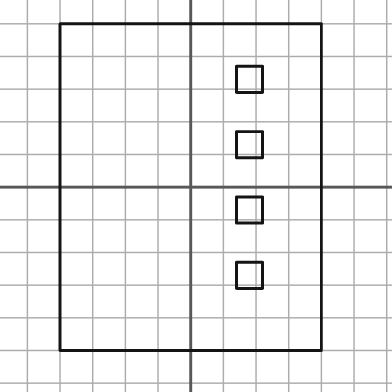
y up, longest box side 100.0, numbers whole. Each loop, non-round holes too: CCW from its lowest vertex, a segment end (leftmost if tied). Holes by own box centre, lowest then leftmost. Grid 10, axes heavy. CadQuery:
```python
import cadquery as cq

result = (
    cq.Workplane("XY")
    .moveTo(-40.0, -50.0)
    .lineTo(40.0, -50.0)
    .lineTo(40.0, 50.0)
    .lineTo(-40.0, 50.0)
    .close()
    .moveTo(14.0, -31.0)
    .lineTo(22.0, -31.0)
    .lineTo(22.0, -23.0)
    .lineTo(14.0, -23.0)
    .close()
    .moveTo(14.0, -11.0)
    .lineTo(22.0, -11.0)
    .lineTo(22.0, -3.0)
    .lineTo(14.0, -3.0)
    .close()
    .moveTo(14.0, 9.0)
    .lineTo(22.0, 9.0)
    .lineTo(22.0, 17.0)
    .lineTo(14.0, 17.0)
    .close()
    .moveTo(14.0, 29.0)
    .lineTo(22.0, 29.0)
    .lineTo(22.0, 37.0)
    .lineTo(14.0, 37.0)
    .close()
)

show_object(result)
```